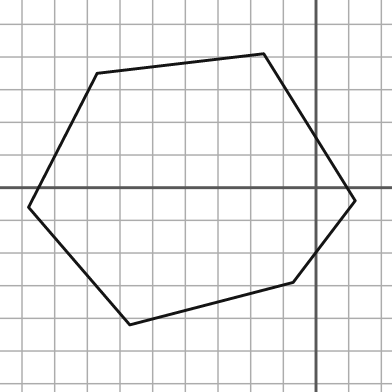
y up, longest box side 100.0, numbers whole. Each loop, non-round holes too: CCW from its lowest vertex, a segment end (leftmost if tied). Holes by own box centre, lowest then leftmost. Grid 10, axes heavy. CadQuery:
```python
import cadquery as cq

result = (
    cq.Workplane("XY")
    .moveTo(-57.0, -42.0)
    .lineTo(-7.0, -29.0)
    .lineTo(12.0, -4.0)
    .lineTo(-16.0, 41.0)
    .lineTo(-67.0, 35.0)
    .lineTo(-88.0, -6.0)
    .close()
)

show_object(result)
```